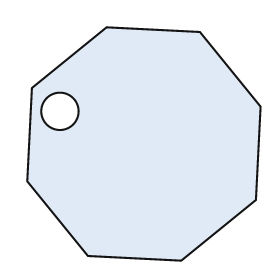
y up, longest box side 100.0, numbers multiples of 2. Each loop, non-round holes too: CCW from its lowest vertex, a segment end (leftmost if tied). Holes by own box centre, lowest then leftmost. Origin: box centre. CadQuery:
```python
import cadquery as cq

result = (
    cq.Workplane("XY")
    .moveTo(16.0, -50.0)
    .lineTo(48.0, -24.0)
    .lineTo(50.0, 16.0)
    .lineTo(24.0, 48.0)
    .lineTo(-16.0, 50.0)
    .lineTo(-48.0, 24.0)
    .lineTo(-50.0, -16.0)
    .lineTo(-24.0, -48.0)
    .close()
    .moveTo(-36.0, 14.0)
    .circle(8.0)
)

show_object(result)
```